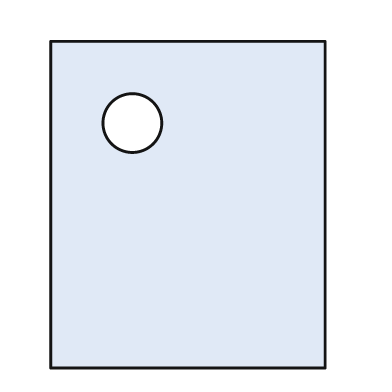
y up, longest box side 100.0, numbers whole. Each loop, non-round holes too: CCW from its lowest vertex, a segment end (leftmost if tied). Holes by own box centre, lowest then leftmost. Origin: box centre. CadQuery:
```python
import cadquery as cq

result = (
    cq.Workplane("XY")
    .moveTo(-42.0, -50.0)
    .lineTo(42.0, -50.0)
    .lineTo(42.0, 50.0)
    .lineTo(-42.0, 50.0)
    .close()
    .moveTo(-17.0, 25.0)
    .circle(9.0)
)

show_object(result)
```